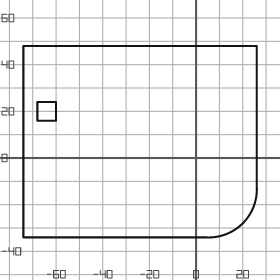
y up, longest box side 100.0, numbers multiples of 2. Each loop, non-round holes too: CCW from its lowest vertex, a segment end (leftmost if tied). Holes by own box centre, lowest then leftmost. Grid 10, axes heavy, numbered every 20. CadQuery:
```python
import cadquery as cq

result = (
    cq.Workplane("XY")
    .moveTo(-74.0, -34.0)
    .lineTo(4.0, -34.0)
    .threePointArc((20.0, -28.0), (26.0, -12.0))
    .lineTo(26.0, 48.0)
    .lineTo(-74.0, 48.0)
    .close()
    .moveTo(-68.0, 16.0)
    .lineTo(-60.0, 16.0)
    .lineTo(-60.0, 24.0)
    .lineTo(-68.0, 24.0)
    .close()
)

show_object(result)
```